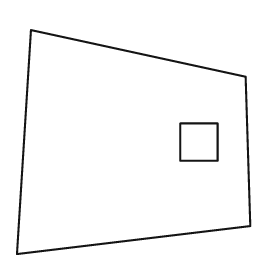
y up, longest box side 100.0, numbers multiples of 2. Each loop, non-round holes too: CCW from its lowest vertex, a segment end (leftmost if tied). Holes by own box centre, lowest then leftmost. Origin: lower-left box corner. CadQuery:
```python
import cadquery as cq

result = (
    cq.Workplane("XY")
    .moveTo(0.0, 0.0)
    .lineTo(100.0, 12.0)
    .lineTo(98.0, 76.0)
    .lineTo(6.0, 96.0)
    .close()
    .moveTo(70.0, 40.0)
    .lineTo(86.0, 40.0)
    .lineTo(86.0, 56.0)
    .lineTo(70.0, 56.0)
    .close()
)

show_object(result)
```